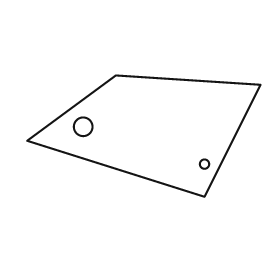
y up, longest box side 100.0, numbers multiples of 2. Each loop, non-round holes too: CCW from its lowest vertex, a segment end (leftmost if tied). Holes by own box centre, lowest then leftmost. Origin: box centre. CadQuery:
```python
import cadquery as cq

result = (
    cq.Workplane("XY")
    .moveTo(26.0, -26.0)
    .lineTo(50.0, 22.0)
    .lineTo(-12.0, 26.0)
    .lineTo(-50.0, -2.0)
    .close()
    .moveTo(26.0, -12.0)
    .circle(2.0)
    .moveTo(-26.0, 4.0)
    .circle(4.0)
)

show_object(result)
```